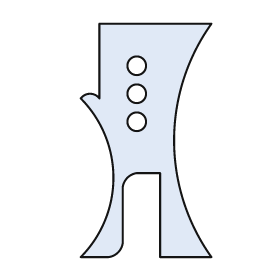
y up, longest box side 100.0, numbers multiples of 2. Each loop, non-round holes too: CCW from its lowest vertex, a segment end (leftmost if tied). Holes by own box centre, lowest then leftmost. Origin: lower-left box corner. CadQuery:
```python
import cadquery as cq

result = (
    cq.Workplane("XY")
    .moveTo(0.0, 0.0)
    .lineTo(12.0, 0.0)
    .threePointArc((16.0, 2.0), (18.0, 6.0))
    .lineTo(18.0, 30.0)
    .threePointArc((20.0, 34.0), (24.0, 36.0))
    .lineTo(34.0, 36.0)
    .lineTo(34.0, 0.0)
    .lineTo(56.0, 0.0)
    .threePointArc((40.0, 50.0), (56.0, 100.0))
    .lineTo(8.0, 100.0)
    .lineTo(8.0, 68.0)
    .threePointArc((4.0, 70.0), (0.0, 68.0))
    .threePointArc((14.0, 34.0), (0.0, 0.0))
    .close()
    .moveTo(24.0, 58.0)
    .circle(4.0)
    .moveTo(24.0, 70.0)
    .circle(4.0)
    .moveTo(24.0, 82.0)
    .circle(4.0)
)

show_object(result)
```